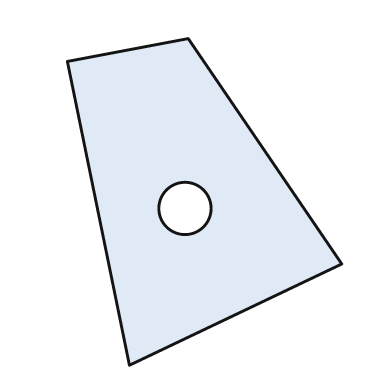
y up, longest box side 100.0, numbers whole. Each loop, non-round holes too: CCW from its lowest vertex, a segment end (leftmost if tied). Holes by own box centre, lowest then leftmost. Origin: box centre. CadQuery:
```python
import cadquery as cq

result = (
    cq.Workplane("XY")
    .moveTo(-23.0, -50.0)
    .lineTo(42.0, -19.0)
    .lineTo(-5.0, 50.0)
    .lineTo(-42.0, 43.0)
    .close()
    .moveTo(-6.0, -2.0)
    .circle(8.0)
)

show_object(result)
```